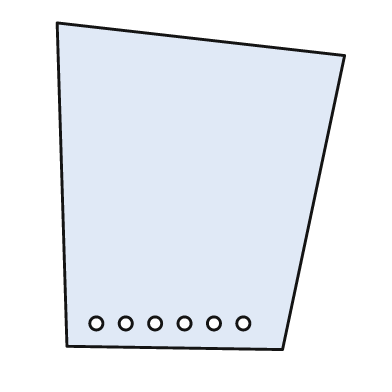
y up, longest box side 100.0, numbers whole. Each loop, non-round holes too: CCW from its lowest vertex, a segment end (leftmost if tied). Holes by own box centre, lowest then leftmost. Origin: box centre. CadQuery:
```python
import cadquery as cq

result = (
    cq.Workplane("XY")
    .moveTo(25.0, -50.0)
    .lineTo(44.0, 40.0)
    .lineTo(-44.0, 50.0)
    .lineTo(-41.0, -49.0)
    .close()
    .moveTo(-32.0, -42.0)
    .circle(2.0)
    .moveTo(-23.0, -42.0)
    .circle(2.0)
    .moveTo(-14.0, -42.0)
    .circle(2.0)
    .moveTo(-5.0, -42.0)
    .circle(2.0)
    .moveTo(4.0, -42.0)
    .circle(2.0)
    .moveTo(13.0, -42.0)
    .circle(2.0)
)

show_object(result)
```